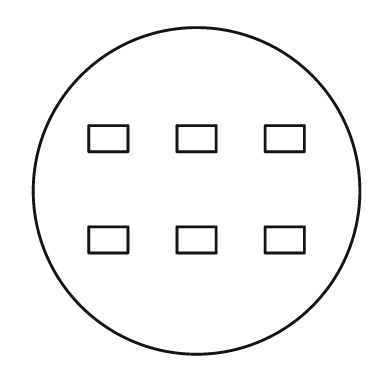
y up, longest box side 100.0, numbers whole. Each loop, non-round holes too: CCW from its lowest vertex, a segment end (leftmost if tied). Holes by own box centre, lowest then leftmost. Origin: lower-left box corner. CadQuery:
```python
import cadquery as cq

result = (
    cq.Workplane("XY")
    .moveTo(50.0, 50.0)
    .circle(50.0)
    .moveTo(17.0, 31.0)
    .lineTo(29.0, 31.0)
    .lineTo(29.0, 39.0)
    .lineTo(17.0, 39.0)
    .close()
    .moveTo(44.0, 31.0)
    .lineTo(56.0, 31.0)
    .lineTo(56.0, 39.0)
    .lineTo(44.0, 39.0)
    .close()
    .moveTo(71.0, 31.0)
    .lineTo(83.0, 31.0)
    .lineTo(83.0, 39.0)
    .lineTo(71.0, 39.0)
    .close()
    .moveTo(17.0, 62.0)
    .lineTo(29.0, 62.0)
    .lineTo(29.0, 70.0)
    .lineTo(17.0, 70.0)
    .close()
    .moveTo(44.0, 62.0)
    .lineTo(56.0, 62.0)
    .lineTo(56.0, 70.0)
    .lineTo(44.0, 70.0)
    .close()
    .moveTo(71.0, 62.0)
    .lineTo(83.0, 62.0)
    .lineTo(83.0, 70.0)
    .lineTo(71.0, 70.0)
    .close()
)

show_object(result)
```